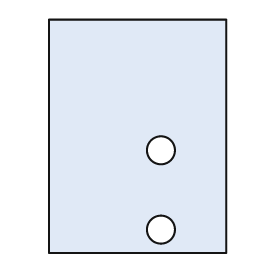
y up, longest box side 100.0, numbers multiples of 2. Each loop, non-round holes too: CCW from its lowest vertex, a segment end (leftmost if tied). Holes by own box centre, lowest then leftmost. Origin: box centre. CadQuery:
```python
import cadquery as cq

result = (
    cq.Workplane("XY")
    .moveTo(-38.0, -50.0)
    .lineTo(38.0, -50.0)
    .lineTo(38.0, 50.0)
    .lineTo(-38.0, 50.0)
    .close()
    .moveTo(10.0, -40.0)
    .circle(6.0)
    .moveTo(10.0, -6.0)
    .circle(6.0)
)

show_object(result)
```